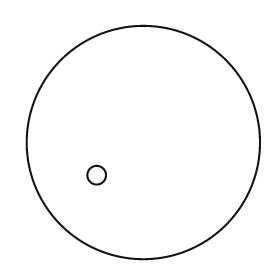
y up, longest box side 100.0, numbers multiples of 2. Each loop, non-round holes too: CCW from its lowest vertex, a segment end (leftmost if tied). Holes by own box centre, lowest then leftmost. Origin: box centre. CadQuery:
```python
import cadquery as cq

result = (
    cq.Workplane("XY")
    .moveTo(0.0, 0.0)
    .circle(50.0)
    .moveTo(-20.0, -14.0)
    .circle(4.0)
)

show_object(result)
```